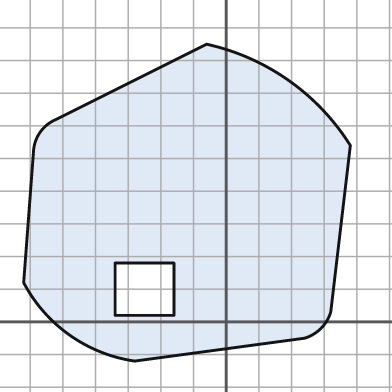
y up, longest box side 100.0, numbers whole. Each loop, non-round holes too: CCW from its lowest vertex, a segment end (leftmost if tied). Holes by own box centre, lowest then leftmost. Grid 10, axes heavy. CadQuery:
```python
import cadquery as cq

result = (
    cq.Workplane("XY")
    .moveTo(-28.0, -12.0)
    .lineTo(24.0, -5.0)
    .threePointArc((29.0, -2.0), (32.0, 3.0))
    .lineTo(38.0, 54.0)
    .threePointArc((19.0, 74.0), (-6.0, 85.0))
    .lineTo(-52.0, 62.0)
    .threePointArc((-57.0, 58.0), (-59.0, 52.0))
    .lineTo(-62.0, 12.0)
    .threePointArc((-48.0, -4.0), (-28.0, -12.0))
    .close()
    .moveTo(-34.0, 2.0)
    .lineTo(-16.0, 2.0)
    .lineTo(-16.0, 18.0)
    .lineTo(-34.0, 18.0)
    .close()
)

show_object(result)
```